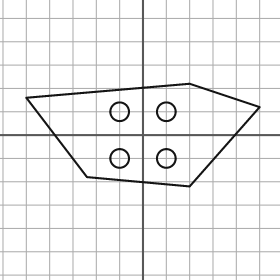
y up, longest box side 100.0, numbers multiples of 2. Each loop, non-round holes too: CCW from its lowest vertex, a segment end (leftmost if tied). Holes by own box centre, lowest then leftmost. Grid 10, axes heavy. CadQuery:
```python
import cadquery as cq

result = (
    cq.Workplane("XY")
    .moveTo(20.0, -22.0)
    .lineTo(50.0, 12.0)
    .lineTo(20.0, 22.0)
    .lineTo(-50.0, 16.0)
    .lineTo(-24.0, -18.0)
    .close()
    .moveTo(-10.0, -10.0)
    .circle(4.0)
    .moveTo(10.0, -10.0)
    .circle(4.0)
    .moveTo(-10.0, 10.0)
    .circle(4.0)
    .moveTo(10.0, 10.0)
    .circle(4.0)
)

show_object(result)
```